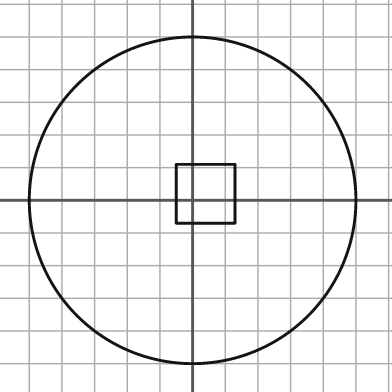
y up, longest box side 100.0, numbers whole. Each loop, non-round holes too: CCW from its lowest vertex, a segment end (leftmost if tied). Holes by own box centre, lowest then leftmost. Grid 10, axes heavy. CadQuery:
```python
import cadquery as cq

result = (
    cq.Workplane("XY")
    .moveTo(0.0, 0.0)
    .circle(50.0)
    .moveTo(-5.0, -7.0)
    .lineTo(13.0, -7.0)
    .lineTo(13.0, 11.0)
    .lineTo(-5.0, 11.0)
    .close()
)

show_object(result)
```